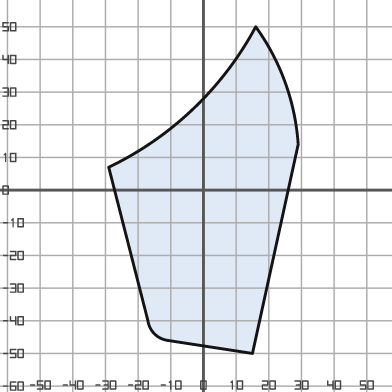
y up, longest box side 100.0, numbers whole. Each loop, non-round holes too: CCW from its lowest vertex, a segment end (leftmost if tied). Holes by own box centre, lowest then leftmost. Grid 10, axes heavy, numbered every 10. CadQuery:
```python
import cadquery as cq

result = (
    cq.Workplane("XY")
    .moveTo(15.0, -50.0)
    .lineTo(29.0, 14.0)
    .threePointArc((25.0, 33.0), (16.0, 50.0))
    .threePointArc((-3.0, 25.0), (-29.0, 7.0))
    .lineTo(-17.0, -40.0)
    .threePointArc((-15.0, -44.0), (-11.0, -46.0))
    .close()
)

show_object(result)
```